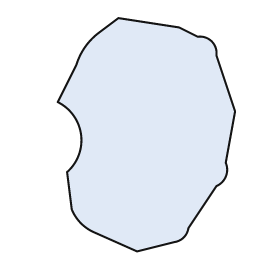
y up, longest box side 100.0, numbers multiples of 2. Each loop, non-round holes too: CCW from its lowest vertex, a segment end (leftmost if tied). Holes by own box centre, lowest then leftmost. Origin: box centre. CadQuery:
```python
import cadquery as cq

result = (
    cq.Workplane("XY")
    .moveTo(-4.0, -50.0)
    .lineTo(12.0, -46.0)
    .threePointArc((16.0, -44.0), (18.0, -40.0))
    .lineTo(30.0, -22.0)
    .threePointArc((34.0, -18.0), (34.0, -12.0))
    .lineTo(38.0, 10.0)
    .lineTo(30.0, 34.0)
    .threePointArc((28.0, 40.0), (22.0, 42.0))
    .lineTo(14.0, 46.0)
    .lineTo(-12.0, 50.0)
    .lineTo(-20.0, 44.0)
    .threePointArc((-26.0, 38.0), (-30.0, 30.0))
    .lineTo(-38.0, 14.0)
    .threePointArc((-28.0, 0.0), (-34.0, -16.0))
    .lineTo(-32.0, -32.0)
    .threePointArc((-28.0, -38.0), (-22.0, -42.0))
    .close()
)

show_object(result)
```